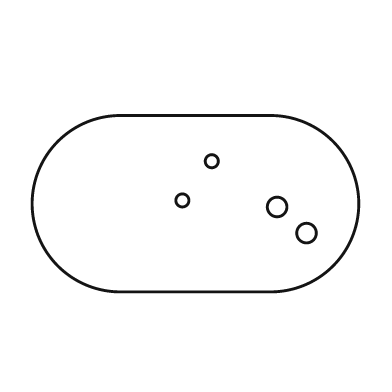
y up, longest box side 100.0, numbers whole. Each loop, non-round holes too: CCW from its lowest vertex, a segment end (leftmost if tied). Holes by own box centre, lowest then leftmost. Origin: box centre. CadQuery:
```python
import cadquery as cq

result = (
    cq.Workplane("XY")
    .moveTo(-23.0, -27.0)
    .lineTo(23.0, -27.0)
    .threePointArc((50.0, 0.0), (23.0, 27.0))
    .lineTo(-23.0, 27.0)
    .threePointArc((-50.0, 0.0), (-23.0, -27.0))
    .close()
    .moveTo(34.0, -9.0)
    .circle(3.0)
    .moveTo(25.0, -1.0)
    .circle(3.0)
    .moveTo(-4.0, 1.0)
    .circle(2.0)
    .moveTo(5.0, 13.0)
    .circle(2.0)
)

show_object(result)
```